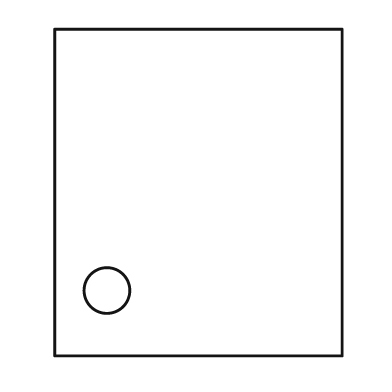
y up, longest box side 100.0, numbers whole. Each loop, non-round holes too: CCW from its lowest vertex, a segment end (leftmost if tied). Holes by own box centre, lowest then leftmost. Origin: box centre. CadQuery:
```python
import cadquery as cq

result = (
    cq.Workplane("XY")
    .moveTo(-44.0, -50.0)
    .lineTo(44.0, -50.0)
    .lineTo(44.0, 50.0)
    .lineTo(-44.0, 50.0)
    .close()
    .moveTo(-28.0, -30.0)
    .circle(7.0)
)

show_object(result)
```